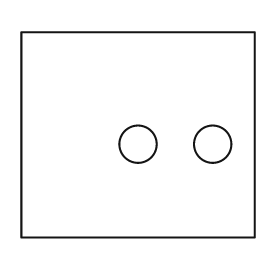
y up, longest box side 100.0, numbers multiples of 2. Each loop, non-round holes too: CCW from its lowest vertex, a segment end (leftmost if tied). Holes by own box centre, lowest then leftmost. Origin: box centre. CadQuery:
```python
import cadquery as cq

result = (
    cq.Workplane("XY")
    .moveTo(-50.0, -44.0)
    .lineTo(50.0, -44.0)
    .lineTo(50.0, 44.0)
    .lineTo(-50.0, 44.0)
    .close()
    .moveTo(0.0, -4.0)
    .circle(8.0)
    .moveTo(32.0, -4.0)
    .circle(8.0)
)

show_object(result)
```